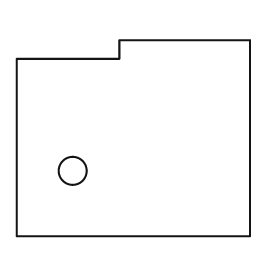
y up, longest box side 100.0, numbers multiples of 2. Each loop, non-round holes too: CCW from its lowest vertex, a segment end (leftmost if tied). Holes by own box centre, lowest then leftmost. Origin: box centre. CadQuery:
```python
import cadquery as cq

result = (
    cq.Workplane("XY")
    .moveTo(-50.0, -42.0)
    .lineTo(50.0, -42.0)
    .lineTo(50.0, 42.0)
    .lineTo(-6.0, 42.0)
    .lineTo(-6.0, 34.0)
    .lineTo(-50.0, 34.0)
    .close()
    .moveTo(-26.0, -14.0)
    .circle(6.0)
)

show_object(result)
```